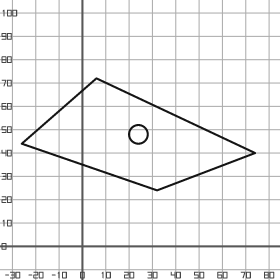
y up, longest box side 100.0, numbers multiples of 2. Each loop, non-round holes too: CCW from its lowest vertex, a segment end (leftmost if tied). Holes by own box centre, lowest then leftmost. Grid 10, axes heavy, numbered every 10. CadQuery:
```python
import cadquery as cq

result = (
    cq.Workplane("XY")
    .moveTo(32.0, 24.0)
    .lineTo(74.0, 40.0)
    .lineTo(6.0, 72.0)
    .lineTo(-26.0, 44.0)
    .close()
    .moveTo(24.0, 48.0)
    .circle(4.0)
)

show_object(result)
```